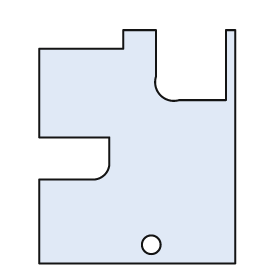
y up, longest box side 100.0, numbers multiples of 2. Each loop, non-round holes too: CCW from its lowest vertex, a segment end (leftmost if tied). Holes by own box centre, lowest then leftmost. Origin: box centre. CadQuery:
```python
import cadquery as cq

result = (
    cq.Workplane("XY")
    .moveTo(-42.0, -50.0)
    .lineTo(42.0, -50.0)
    .lineTo(42.0, 50.0)
    .lineTo(38.0, 50.0)
    .lineTo(38.0, 20.0)
    .lineTo(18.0, 20.0)
    .threePointArc((10.0, 22.0), (8.0, 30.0))
    .lineTo(8.0, 50.0)
    .lineTo(-6.0, 50.0)
    .lineTo(-6.0, 42.0)
    .lineTo(-42.0, 42.0)
    .lineTo(-42.0, 4.0)
    .lineTo(-12.0, 4.0)
    .lineTo(-12.0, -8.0)
    .threePointArc((-14.0, -12.0), (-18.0, -14.0))
    .lineTo(-42.0, -14.0)
    .close()
    .moveTo(6.0, -42.0)
    .circle(4.0)
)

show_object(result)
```